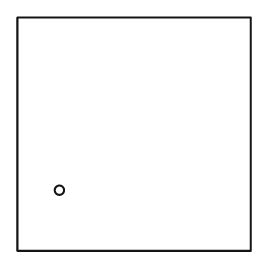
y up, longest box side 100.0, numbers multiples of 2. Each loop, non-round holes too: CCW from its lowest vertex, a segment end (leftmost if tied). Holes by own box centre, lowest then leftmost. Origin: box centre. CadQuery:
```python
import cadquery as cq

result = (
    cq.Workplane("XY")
    .moveTo(-50.0, -50.0)
    .lineTo(50.0, -50.0)
    .lineTo(50.0, 50.0)
    .lineTo(-50.0, 50.0)
    .close()
    .moveTo(-32.0, -24.0)
    .circle(2.0)
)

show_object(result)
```